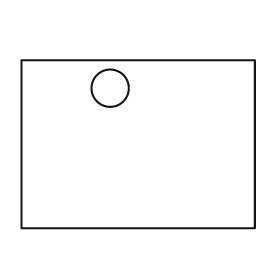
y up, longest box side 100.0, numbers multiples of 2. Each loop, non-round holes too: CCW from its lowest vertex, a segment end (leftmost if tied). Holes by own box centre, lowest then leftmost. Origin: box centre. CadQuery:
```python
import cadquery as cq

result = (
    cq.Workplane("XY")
    .moveTo(-50.0, -36.0)
    .lineTo(50.0, -36.0)
    .lineTo(50.0, 36.0)
    .lineTo(-50.0, 36.0)
    .close()
    .moveTo(-12.0, 24.0)
    .circle(8.0)
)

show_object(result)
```